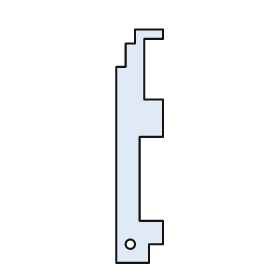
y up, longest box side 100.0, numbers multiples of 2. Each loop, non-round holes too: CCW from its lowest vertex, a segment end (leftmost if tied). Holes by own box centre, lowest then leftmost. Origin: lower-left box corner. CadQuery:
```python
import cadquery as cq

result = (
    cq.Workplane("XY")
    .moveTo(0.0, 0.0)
    .lineTo(14.0, 0.0)
    .lineTo(14.0, 8.0)
    .lineTo(20.0, 8.0)
    .lineTo(20.0, 18.0)
    .lineTo(10.0, 18.0)
    .lineTo(10.0, 54.0)
    .lineTo(20.0, 54.0)
    .lineTo(20.0, 70.0)
    .lineTo(12.0, 70.0)
    .lineTo(12.0, 96.0)
    .lineTo(20.0, 96.0)
    .lineTo(20.0, 100.0)
    .lineTo(8.0, 100.0)
    .lineTo(8.0, 94.0)
    .lineTo(4.0, 94.0)
    .lineTo(4.0, 84.0)
    .lineTo(0.0, 84.0)
    .close()
    .moveTo(6.0, 8.0)
    .circle(2.0)
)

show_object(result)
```